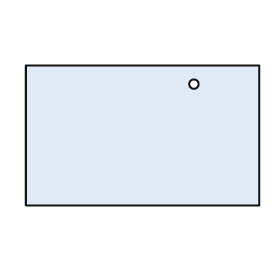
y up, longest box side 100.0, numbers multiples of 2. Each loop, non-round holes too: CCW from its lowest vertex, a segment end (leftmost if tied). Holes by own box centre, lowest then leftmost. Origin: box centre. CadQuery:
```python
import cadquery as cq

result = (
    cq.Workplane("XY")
    .moveTo(-50.0, -30.0)
    .lineTo(50.0, -30.0)
    .lineTo(50.0, 30.0)
    .lineTo(-50.0, 30.0)
    .close()
    .moveTo(22.0, 22.0)
    .circle(2.0)
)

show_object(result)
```